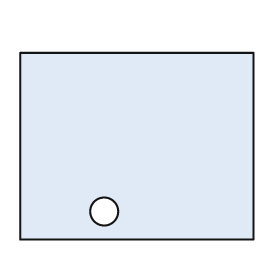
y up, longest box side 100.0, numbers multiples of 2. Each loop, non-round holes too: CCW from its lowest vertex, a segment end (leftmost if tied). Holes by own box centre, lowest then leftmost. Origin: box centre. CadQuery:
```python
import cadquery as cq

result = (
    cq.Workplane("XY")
    .moveTo(-50.0, -40.0)
    .lineTo(50.0, -40.0)
    .lineTo(50.0, 40.0)
    .lineTo(-50.0, 40.0)
    .close()
    .moveTo(-14.0, -28.0)
    .circle(6.0)
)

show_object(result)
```